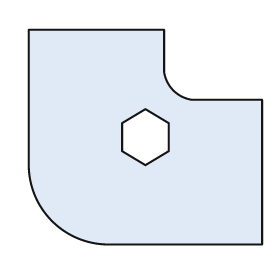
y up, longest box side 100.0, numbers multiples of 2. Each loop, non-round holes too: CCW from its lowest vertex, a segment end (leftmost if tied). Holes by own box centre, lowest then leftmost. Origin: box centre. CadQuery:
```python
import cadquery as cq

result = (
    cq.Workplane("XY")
    .moveTo(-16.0, -46.0)
    .lineTo(50.0, -46.0)
    .lineTo(50.0, 16.0)
    .lineTo(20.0, 16.0)
    .threePointArc((12.0, 20.0), (8.0, 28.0))
    .lineTo(8.0, 46.0)
    .lineTo(-50.0, 46.0)
    .lineTo(-50.0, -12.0)
    .threePointArc((-40.0, -36.0), (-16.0, -46.0))
    .close()
    .moveTo(0.0, -12.0)
    .lineTo(10.0, -6.0)
    .lineTo(10.0, 6.0)
    .lineTo(0.0, 12.0)
    .lineTo(-10.0, 6.0)
    .lineTo(-10.0, -6.0)
    .close()
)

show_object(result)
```